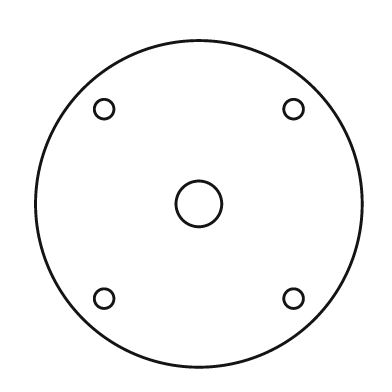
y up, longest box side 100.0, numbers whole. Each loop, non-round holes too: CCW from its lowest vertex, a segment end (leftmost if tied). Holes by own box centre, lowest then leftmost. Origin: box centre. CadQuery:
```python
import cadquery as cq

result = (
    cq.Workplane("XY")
    .moveTo(0.0, 0.0)
    .circle(50.0)
    .moveTo(-29.0, -29.0)
    .circle(3.0)
    .moveTo(29.0, -29.0)
    .circle(3.0)
    .moveTo(0.0, 0.0)
    .circle(7.0)
    .moveTo(-29.0, 29.0)
    .circle(3.0)
    .moveTo(29.0, 29.0)
    .circle(3.0)
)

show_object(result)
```